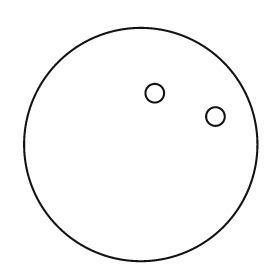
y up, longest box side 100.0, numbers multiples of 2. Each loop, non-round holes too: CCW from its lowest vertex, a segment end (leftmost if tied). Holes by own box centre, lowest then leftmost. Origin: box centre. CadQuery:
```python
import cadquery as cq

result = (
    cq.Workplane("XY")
    .moveTo(0.0, 0.0)
    .circle(50.0)
    .moveTo(32.0, 12.0)
    .circle(4.0)
    .moveTo(6.0, 22.0)
    .circle(4.0)
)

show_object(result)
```